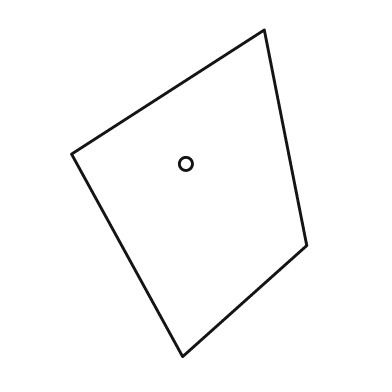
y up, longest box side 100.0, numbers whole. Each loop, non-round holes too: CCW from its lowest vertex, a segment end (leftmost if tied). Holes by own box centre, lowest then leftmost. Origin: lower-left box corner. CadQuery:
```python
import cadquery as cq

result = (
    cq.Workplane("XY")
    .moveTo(34.0, 0.0)
    .lineTo(72.0, 34.0)
    .lineTo(59.0, 100.0)
    .lineTo(0.0, 62.0)
    .close()
    .moveTo(35.0, 59.0)
    .circle(2.0)
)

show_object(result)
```